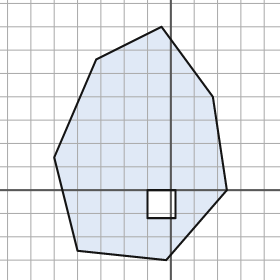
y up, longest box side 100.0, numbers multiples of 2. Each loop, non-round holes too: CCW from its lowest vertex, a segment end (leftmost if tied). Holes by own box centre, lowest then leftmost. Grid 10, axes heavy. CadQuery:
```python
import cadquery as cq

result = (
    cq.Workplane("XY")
    .moveTo(-2.0, -30.0)
    .lineTo(24.0, 0.0)
    .lineTo(18.0, 40.0)
    .lineTo(-4.0, 70.0)
    .lineTo(-32.0, 56.0)
    .lineTo(-50.0, 14.0)
    .lineTo(-40.0, -26.0)
    .close()
    .moveTo(-10.0, -12.0)
    .lineTo(2.0, -12.0)
    .lineTo(2.0, 0.0)
    .lineTo(-10.0, 0.0)
    .close()
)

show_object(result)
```